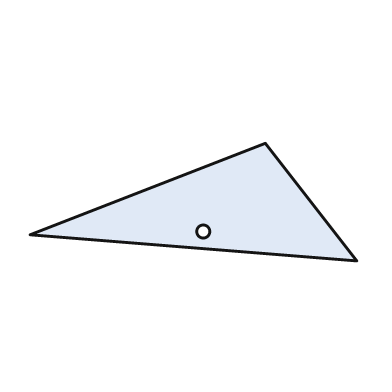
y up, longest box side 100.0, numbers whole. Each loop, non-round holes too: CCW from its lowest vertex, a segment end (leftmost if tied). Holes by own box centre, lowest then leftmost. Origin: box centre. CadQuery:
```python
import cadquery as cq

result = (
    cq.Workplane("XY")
    .moveTo(50.0, -18.0)
    .lineTo(22.0, 18.0)
    .lineTo(-50.0, -10.0)
    .close()
    .moveTo(3.0, -9.0)
    .circle(2.0)
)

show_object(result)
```